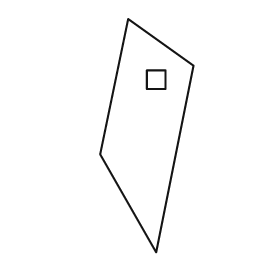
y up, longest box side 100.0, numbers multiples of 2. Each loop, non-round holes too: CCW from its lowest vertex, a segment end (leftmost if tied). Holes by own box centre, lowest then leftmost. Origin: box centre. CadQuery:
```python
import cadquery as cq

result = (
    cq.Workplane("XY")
    .moveTo(4.0, -50.0)
    .lineTo(20.0, 30.0)
    .lineTo(-8.0, 50.0)
    .lineTo(-20.0, -8.0)
    .close()
    .moveTo(0.0, 20.0)
    .lineTo(8.0, 20.0)
    .lineTo(8.0, 28.0)
    .lineTo(0.0, 28.0)
    .close()
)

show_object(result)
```